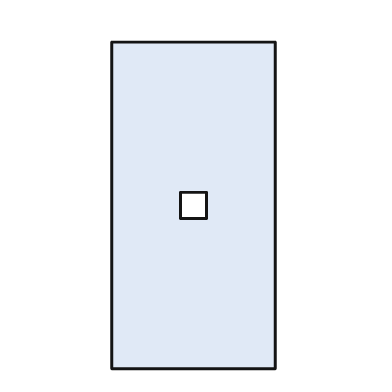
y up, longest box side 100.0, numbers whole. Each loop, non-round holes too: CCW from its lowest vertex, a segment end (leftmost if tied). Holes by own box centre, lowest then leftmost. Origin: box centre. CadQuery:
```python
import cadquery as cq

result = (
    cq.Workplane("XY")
    .moveTo(-25.0, -50.0)
    .lineTo(25.0, -50.0)
    .lineTo(25.0, 50.0)
    .lineTo(-25.0, 50.0)
    .close()
    .moveTo(-4.0, -4.0)
    .lineTo(4.0, -4.0)
    .lineTo(4.0, 4.0)
    .lineTo(-4.0, 4.0)
    .close()
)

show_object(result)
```